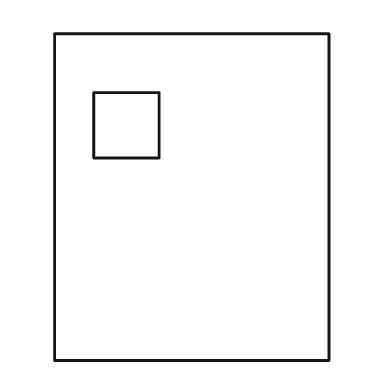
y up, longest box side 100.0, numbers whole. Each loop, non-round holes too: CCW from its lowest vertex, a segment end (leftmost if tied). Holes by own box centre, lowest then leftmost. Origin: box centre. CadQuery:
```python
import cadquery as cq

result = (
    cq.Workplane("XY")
    .moveTo(-42.0, -50.0)
    .lineTo(42.0, -50.0)
    .lineTo(42.0, 50.0)
    .lineTo(-42.0, 50.0)
    .close()
    .moveTo(-30.0, 12.0)
    .lineTo(-10.0, 12.0)
    .lineTo(-10.0, 32.0)
    .lineTo(-30.0, 32.0)
    .close()
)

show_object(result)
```